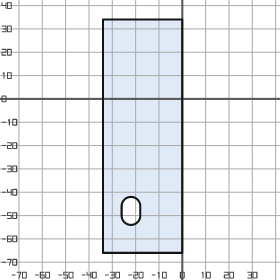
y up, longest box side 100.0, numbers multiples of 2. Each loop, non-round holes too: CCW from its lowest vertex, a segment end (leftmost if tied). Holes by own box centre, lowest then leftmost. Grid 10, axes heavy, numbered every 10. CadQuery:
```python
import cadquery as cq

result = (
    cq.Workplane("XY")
    .moveTo(-34.0, -66.0)
    .lineTo(0.0, -66.0)
    .lineTo(0.0, 34.0)
    .lineTo(-34.0, 34.0)
    .close()
    .moveTo(-26.0, -50.0)
    .threePointArc((-22.0, -54.0), (-18.0, -50.0))
    .lineTo(-18.0, -46.0)
    .threePointArc((-22.0, -42.0), (-26.0, -46.0))
    .close()
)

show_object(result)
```